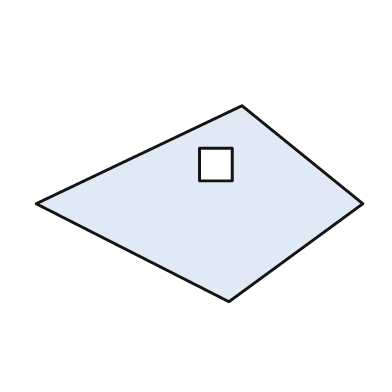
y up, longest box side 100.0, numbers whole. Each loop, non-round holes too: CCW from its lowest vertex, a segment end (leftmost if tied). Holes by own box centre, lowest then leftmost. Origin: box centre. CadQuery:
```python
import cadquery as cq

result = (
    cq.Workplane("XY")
    .moveTo(9.0, -30.0)
    .lineTo(50.0, 0.0)
    .lineTo(13.0, 30.0)
    .lineTo(-50.0, 0.0)
    .close()
    .moveTo(0.0, 7.0)
    .lineTo(10.0, 7.0)
    .lineTo(10.0, 17.0)
    .lineTo(0.0, 17.0)
    .close()
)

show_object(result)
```